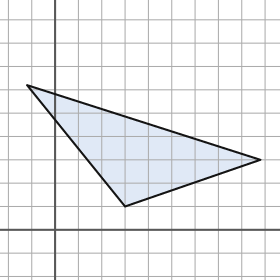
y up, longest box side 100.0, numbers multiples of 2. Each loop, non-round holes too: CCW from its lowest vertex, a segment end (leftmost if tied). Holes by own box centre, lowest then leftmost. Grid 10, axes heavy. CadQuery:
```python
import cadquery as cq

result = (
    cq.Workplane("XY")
    .moveTo(30.0, 10.0)
    .lineTo(88.0, 30.0)
    .lineTo(-12.0, 62.0)
    .close()
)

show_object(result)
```